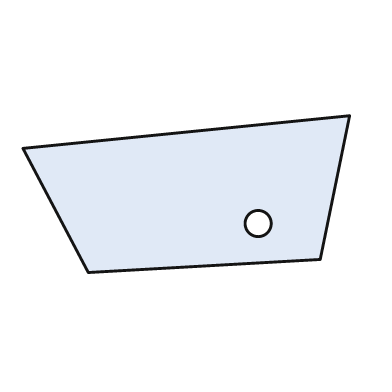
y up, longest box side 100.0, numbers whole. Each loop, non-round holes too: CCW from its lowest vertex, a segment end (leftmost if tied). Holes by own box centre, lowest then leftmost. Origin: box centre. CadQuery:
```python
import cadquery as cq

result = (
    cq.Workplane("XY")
    .moveTo(-30.0, -24.0)
    .lineTo(41.0, -20.0)
    .lineTo(50.0, 24.0)
    .lineTo(-50.0, 14.0)
    .close()
    .moveTo(22.0, -9.0)
    .circle(4.0)
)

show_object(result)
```